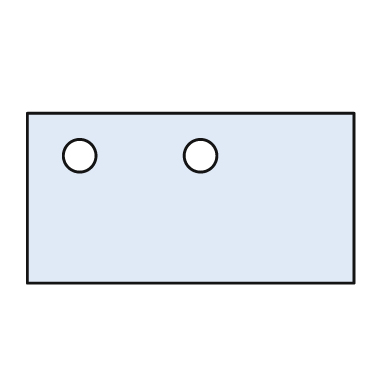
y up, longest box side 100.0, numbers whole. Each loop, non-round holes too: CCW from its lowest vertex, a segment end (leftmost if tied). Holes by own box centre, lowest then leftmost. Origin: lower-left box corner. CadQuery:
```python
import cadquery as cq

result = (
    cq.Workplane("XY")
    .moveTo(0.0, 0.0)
    .lineTo(100.0, 0.0)
    .lineTo(100.0, 52.0)
    .lineTo(0.0, 52.0)
    .close()
    .moveTo(16.0, 39.0)
    .circle(5.0)
    .moveTo(53.0, 39.0)
    .circle(5.0)
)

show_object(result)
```